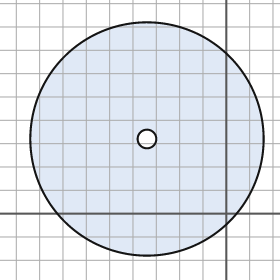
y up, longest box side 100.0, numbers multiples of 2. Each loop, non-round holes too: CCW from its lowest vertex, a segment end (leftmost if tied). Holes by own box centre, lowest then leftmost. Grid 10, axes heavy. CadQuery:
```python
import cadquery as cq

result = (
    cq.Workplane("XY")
    .moveTo(-34.0, 32.0)
    .circle(50.0)
    .moveTo(-34.0, 32.0)
    .circle(4.0)
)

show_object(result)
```